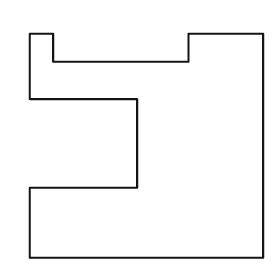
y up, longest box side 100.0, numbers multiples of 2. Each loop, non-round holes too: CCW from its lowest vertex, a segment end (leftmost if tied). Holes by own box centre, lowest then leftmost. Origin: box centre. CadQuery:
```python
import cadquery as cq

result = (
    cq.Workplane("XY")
    .moveTo(-50.0, -48.0)
    .lineTo(50.0, -48.0)
    .lineTo(50.0, 48.0)
    .lineTo(18.0, 48.0)
    .lineTo(18.0, 36.0)
    .lineTo(-40.0, 36.0)
    .lineTo(-40.0, 48.0)
    .lineTo(-50.0, 48.0)
    .lineTo(-50.0, 20.0)
    .lineTo(-4.0, 20.0)
    .lineTo(-4.0, -18.0)
    .lineTo(-50.0, -18.0)
    .close()
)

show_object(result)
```